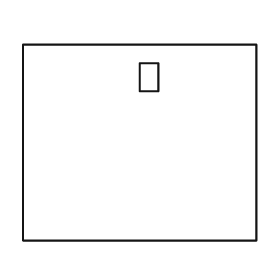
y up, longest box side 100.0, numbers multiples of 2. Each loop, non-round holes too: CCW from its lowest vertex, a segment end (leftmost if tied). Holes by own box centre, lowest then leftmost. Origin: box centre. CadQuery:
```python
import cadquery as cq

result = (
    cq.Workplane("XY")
    .moveTo(-50.0, -42.0)
    .lineTo(50.0, -42.0)
    .lineTo(50.0, 42.0)
    .lineTo(-50.0, 42.0)
    .close()
    .moveTo(0.0, 22.0)
    .lineTo(8.0, 22.0)
    .lineTo(8.0, 34.0)
    .lineTo(0.0, 34.0)
    .close()
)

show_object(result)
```